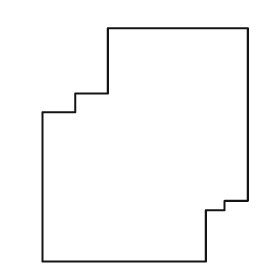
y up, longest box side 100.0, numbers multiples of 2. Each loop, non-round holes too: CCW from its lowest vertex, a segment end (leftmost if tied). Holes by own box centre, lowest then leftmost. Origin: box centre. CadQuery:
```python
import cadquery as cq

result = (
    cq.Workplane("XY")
    .moveTo(-44.0, -50.0)
    .lineTo(26.0, -50.0)
    .lineTo(26.0, -28.0)
    .lineTo(34.0, -28.0)
    .lineTo(34.0, -24.0)
    .lineTo(44.0, -24.0)
    .lineTo(44.0, 50.0)
    .lineTo(-16.0, 50.0)
    .lineTo(-16.0, 22.0)
    .lineTo(-30.0, 22.0)
    .lineTo(-30.0, 14.0)
    .lineTo(-44.0, 14.0)
    .close()
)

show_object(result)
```